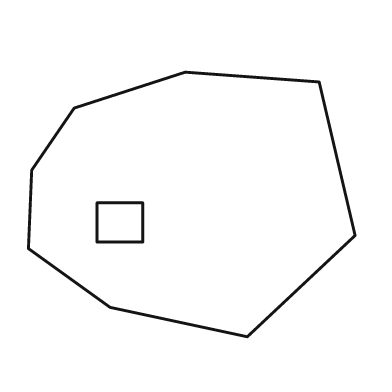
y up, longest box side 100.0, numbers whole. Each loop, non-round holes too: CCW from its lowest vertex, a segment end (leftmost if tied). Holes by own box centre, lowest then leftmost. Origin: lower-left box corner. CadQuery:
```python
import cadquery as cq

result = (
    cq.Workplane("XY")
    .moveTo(67.0, 0.0)
    .lineTo(100.0, 31.0)
    .lineTo(89.0, 78.0)
    .lineTo(48.0, 81.0)
    .lineTo(14.0, 70.0)
    .lineTo(1.0, 51.0)
    .lineTo(0.0, 27.0)
    .lineTo(25.0, 9.0)
    .close()
    .moveTo(21.0, 29.0)
    .lineTo(35.0, 29.0)
    .lineTo(35.0, 41.0)
    .lineTo(21.0, 41.0)
    .close()
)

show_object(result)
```